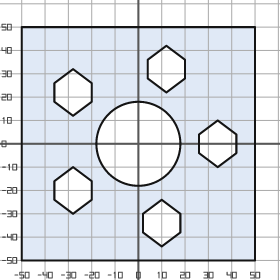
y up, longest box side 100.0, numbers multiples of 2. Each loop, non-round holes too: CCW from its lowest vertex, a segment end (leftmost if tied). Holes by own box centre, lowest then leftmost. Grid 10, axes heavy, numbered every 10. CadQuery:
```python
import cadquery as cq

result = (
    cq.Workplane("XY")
    .moveTo(-50.0, -50.0)
    .lineTo(50.0, -50.0)
    .lineTo(50.0, 50.0)
    .lineTo(-50.0, 50.0)
    .close()
    .moveTo(10.0, -44.0)
    .lineTo(18.0, -38.0)
    .lineTo(18.0, -30.0)
    .lineTo(10.0, -24.0)
    .lineTo(2.0, -30.0)
    .lineTo(2.0, -38.0)
    .close()
    .moveTo(-28.0, -30.0)
    .lineTo(-20.0, -24.0)
    .lineTo(-20.0, -16.0)
    .lineTo(-28.0, -10.0)
    .lineTo(-36.0, -16.0)
    .lineTo(-36.0, -24.0)
    .close()
    .moveTo(0.0, 0.0)
    .circle(18.0)
    .moveTo(34.0, -10.0)
    .lineTo(42.0, -4.0)
    .lineTo(42.0, 4.0)
    .lineTo(34.0, 10.0)
    .lineTo(26.0, 4.0)
    .lineTo(26.0, -4.0)
    .close()
    .moveTo(-28.0, 12.0)
    .lineTo(-20.0, 18.0)
    .lineTo(-20.0, 26.0)
    .lineTo(-28.0, 32.0)
    .lineTo(-36.0, 26.0)
    .lineTo(-36.0, 18.0)
    .close()
    .moveTo(12.0, 22.0)
    .lineTo(20.0, 28.0)
    .lineTo(20.0, 36.0)
    .lineTo(12.0, 42.0)
    .lineTo(4.0, 36.0)
    .lineTo(4.0, 28.0)
    .close()
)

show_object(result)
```